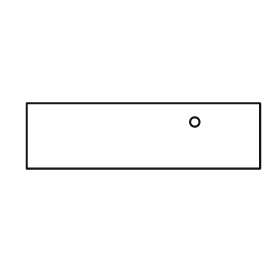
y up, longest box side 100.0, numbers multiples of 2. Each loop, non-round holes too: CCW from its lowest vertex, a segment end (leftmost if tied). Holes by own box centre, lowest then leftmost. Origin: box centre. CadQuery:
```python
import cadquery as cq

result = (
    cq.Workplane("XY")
    .moveTo(-50.0, -14.0)
    .lineTo(50.0, -14.0)
    .lineTo(50.0, 14.0)
    .lineTo(-50.0, 14.0)
    .close()
    .moveTo(22.0, 6.0)
    .circle(2.0)
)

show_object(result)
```